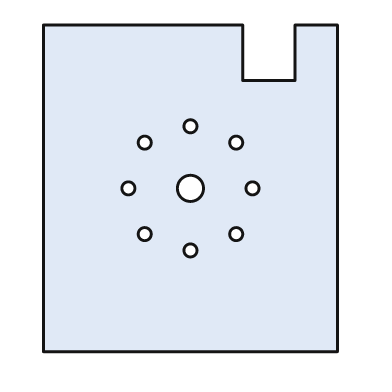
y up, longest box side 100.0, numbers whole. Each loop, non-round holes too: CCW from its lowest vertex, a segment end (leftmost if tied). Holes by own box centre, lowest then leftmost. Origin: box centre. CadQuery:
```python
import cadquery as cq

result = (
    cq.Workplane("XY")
    .moveTo(-45.0, -50.0)
    .lineTo(45.0, -50.0)
    .lineTo(45.0, 50.0)
    .lineTo(32.0, 50.0)
    .lineTo(32.0, 33.0)
    .lineTo(16.0, 33.0)
    .lineTo(16.0, 50.0)
    .lineTo(-45.0, 50.0)
    .close()
    .moveTo(0.0, -19.0)
    .circle(2.0)
    .moveTo(-14.0, -14.0)
    .circle(2.0)
    .moveTo(14.0, -14.0)
    .circle(2.0)
    .moveTo(-19.0, 0.0)
    .circle(2.0)
    .moveTo(0.0, 0.0)
    .circle(4.0)
    .moveTo(19.0, 0.0)
    .circle(2.0)
    .moveTo(-14.0, 14.0)
    .circle(2.0)
    .moveTo(14.0, 14.0)
    .circle(2.0)
    .moveTo(0.0, 19.0)
    .circle(2.0)
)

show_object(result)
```